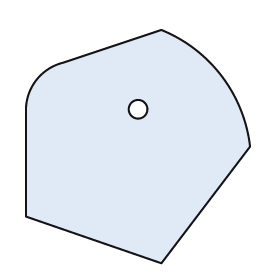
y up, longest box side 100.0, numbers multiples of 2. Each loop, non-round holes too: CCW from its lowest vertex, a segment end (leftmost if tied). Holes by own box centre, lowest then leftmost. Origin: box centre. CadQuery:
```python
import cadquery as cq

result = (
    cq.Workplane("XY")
    .moveTo(10.0, -50.0)
    .lineTo(48.0, 0.0)
    .threePointArc((36.0, 30.0), (10.0, 50.0))
    .lineTo(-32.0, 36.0)
    .threePointArc((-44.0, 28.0), (-48.0, 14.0))
    .lineTo(-48.0, -30.0)
    .close()
    .moveTo(0.0, 16.0)
    .circle(4.0)
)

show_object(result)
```